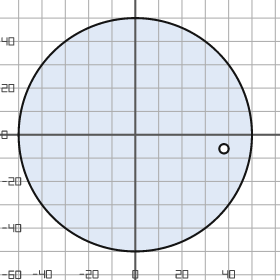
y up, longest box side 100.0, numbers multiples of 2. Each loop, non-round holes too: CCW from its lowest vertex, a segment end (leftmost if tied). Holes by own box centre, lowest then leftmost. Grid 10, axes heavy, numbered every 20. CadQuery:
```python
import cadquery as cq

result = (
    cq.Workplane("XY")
    .moveTo(0.0, 0.0)
    .circle(50.0)
    .moveTo(38.0, -6.0)
    .circle(2.0)
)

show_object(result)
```